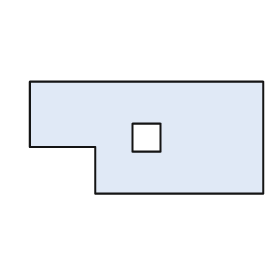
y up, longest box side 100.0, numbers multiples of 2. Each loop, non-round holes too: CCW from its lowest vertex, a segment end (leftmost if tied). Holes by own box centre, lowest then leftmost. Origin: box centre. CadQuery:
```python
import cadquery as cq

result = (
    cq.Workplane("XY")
    .moveTo(-22.0, -24.0)
    .lineTo(50.0, -24.0)
    .lineTo(50.0, 24.0)
    .lineTo(-50.0, 24.0)
    .lineTo(-50.0, -4.0)
    .lineTo(-22.0, -4.0)
    .close()
    .moveTo(-6.0, -6.0)
    .lineTo(6.0, -6.0)
    .lineTo(6.0, 6.0)
    .lineTo(-6.0, 6.0)
    .close()
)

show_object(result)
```